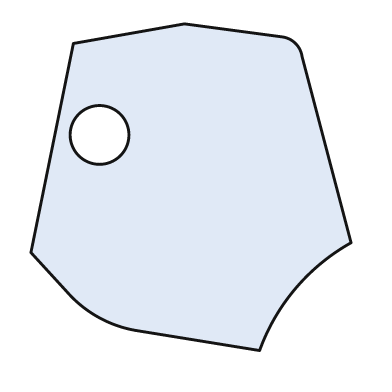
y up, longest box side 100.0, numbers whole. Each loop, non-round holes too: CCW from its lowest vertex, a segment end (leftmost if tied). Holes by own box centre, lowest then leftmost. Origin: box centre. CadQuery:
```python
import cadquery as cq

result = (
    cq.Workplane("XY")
    .moveTo(21.0, -50.0)
    .threePointArc((32.0, -31.0), (49.0, -17.0))
    .lineTo(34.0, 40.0)
    .threePointArc((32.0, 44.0), (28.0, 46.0))
    .lineTo(-2.0, 50.0)
    .lineTo(-36.0, 44.0)
    .lineTo(-49.0, -20.0)
    .lineTo(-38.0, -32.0)
    .threePointArc((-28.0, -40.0), (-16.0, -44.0))
    .close()
    .moveTo(-28.0, 16.0)
    .circle(9.0)
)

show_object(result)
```